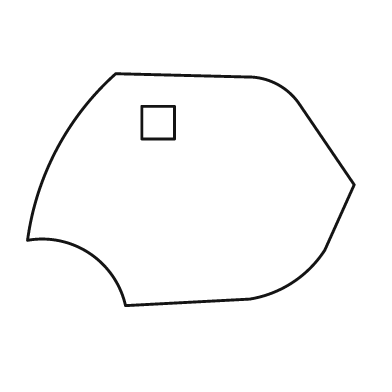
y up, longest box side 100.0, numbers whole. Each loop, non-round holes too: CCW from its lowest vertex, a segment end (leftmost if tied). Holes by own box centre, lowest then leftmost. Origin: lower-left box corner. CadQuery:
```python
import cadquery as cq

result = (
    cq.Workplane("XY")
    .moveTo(30.0, 0.0)
    .lineTo(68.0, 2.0)
    .threePointArc((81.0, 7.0), (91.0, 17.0))
    .lineTo(100.0, 37.0)
    .lineTo(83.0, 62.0)
    .threePointArc((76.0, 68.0), (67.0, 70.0))
    .lineTo(27.0, 71.0)
    .threePointArc((9.0, 48.0), (0.0, 20.0))
    .threePointArc((19.0, 16.0), (30.0, 0.0))
    .close()
    .moveTo(35.0, 51.0)
    .lineTo(45.0, 51.0)
    .lineTo(45.0, 61.0)
    .lineTo(35.0, 61.0)
    .close()
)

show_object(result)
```